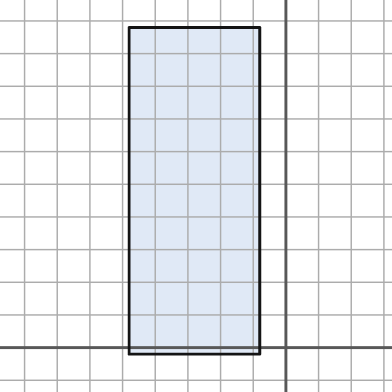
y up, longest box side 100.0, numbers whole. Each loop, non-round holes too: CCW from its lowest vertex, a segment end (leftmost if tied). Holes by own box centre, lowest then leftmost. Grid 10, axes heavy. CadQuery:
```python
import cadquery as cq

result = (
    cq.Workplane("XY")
    .moveTo(-48.0, -2.0)
    .lineTo(-8.0, -2.0)
    .lineTo(-8.0, 98.0)
    .lineTo(-48.0, 98.0)
    .close()
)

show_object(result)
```